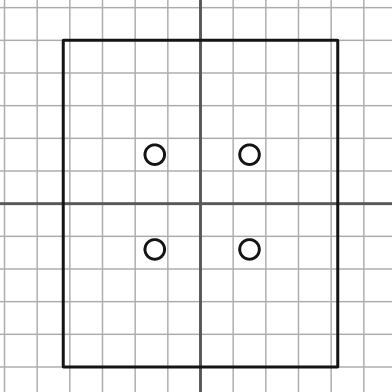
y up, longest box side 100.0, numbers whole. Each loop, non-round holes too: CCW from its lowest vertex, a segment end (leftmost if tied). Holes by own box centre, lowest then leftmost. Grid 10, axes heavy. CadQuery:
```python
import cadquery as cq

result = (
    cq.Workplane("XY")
    .moveTo(-42.0, -50.0)
    .lineTo(42.0, -50.0)
    .lineTo(42.0, 50.0)
    .lineTo(-42.0, 50.0)
    .close()
    .moveTo(-14.0, -14.0)
    .circle(3.0)
    .moveTo(15.0, -14.0)
    .circle(3.0)
    .moveTo(-14.0, 15.0)
    .circle(3.0)
    .moveTo(15.0, 15.0)
    .circle(3.0)
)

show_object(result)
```